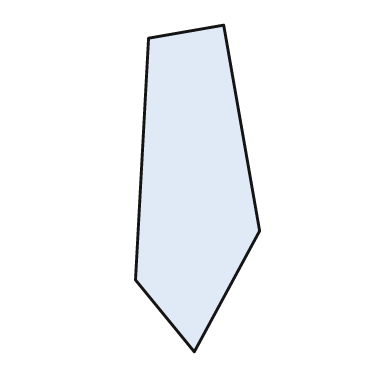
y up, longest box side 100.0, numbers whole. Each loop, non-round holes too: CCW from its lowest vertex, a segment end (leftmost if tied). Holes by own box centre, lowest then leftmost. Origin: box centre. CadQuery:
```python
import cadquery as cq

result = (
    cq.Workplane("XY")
    .moveTo(-1.0, -50.0)
    .lineTo(19.0, -13.0)
    .lineTo(8.0, 50.0)
    .lineTo(-15.0, 46.0)
    .lineTo(-19.0, -28.0)
    .close()
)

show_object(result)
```